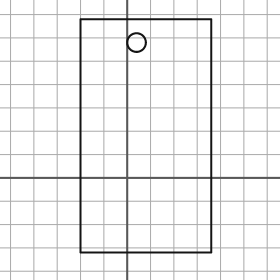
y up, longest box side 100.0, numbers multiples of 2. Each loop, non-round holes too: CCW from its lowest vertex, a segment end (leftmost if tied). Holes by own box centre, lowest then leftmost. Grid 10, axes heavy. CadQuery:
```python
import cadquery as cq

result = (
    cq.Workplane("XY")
    .moveTo(-20.0, -32.0)
    .lineTo(36.0, -32.0)
    .lineTo(36.0, 68.0)
    .lineTo(-20.0, 68.0)
    .close()
    .moveTo(4.0, 58.0)
    .circle(4.0)
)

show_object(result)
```